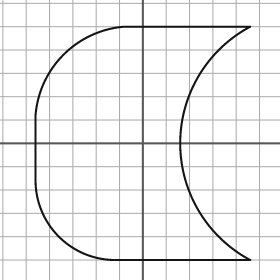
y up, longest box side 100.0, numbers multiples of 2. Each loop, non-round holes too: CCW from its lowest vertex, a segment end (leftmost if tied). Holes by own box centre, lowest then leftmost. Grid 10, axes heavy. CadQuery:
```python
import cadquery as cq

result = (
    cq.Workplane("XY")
    .moveTo(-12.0, -50.0)
    .lineTo(46.0, -50.0)
    .threePointArc((16.0, 0.0), (46.0, 50.0))
    .lineTo(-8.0, 50.0)
    .threePointArc((-34.0, 38.0), (-46.0, 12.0))
    .lineTo(-46.0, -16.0)
    .threePointArc((-36.0, -40.0), (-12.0, -50.0))
    .close()
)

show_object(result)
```